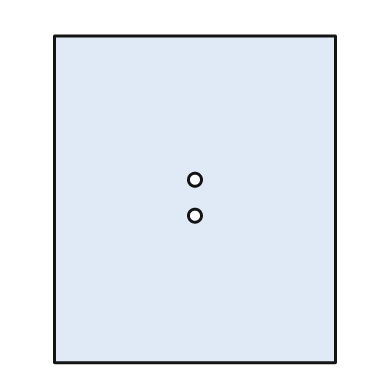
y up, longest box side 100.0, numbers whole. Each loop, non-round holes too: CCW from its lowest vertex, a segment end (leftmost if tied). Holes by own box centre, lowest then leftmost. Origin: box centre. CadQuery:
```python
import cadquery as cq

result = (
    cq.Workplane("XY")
    .moveTo(-43.0, -50.0)
    .lineTo(43.0, -50.0)
    .lineTo(43.0, 50.0)
    .lineTo(-43.0, 50.0)
    .close()
    .moveTo(0.0, -5.0)
    .circle(2.0)
    .moveTo(0.0, 6.0)
    .circle(2.0)
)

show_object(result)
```